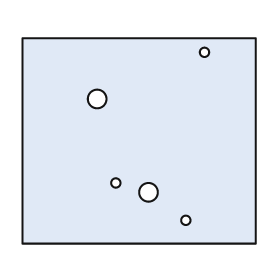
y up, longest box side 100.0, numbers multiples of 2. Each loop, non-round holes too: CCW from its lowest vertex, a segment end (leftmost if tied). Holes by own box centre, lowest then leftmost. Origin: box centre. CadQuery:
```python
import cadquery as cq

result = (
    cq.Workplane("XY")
    .moveTo(-50.0, -44.0)
    .lineTo(50.0, -44.0)
    .lineTo(50.0, 44.0)
    .lineTo(-50.0, 44.0)
    .close()
    .moveTo(20.0, -34.0)
    .circle(2.0)
    .moveTo(4.0, -22.0)
    .circle(4.0)
    .moveTo(-10.0, -18.0)
    .circle(2.0)
    .moveTo(-18.0, 18.0)
    .circle(4.0)
    .moveTo(28.0, 38.0)
    .circle(2.0)
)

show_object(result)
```